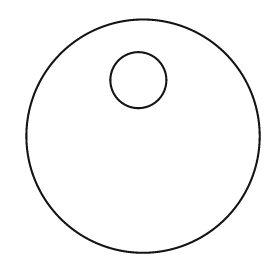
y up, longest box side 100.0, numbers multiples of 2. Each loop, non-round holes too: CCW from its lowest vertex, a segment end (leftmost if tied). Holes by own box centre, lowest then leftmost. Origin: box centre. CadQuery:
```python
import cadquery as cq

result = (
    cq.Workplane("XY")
    .moveTo(0.0, 0.0)
    .circle(50.0)
    .moveTo(-2.0, 24.0)
    .circle(12.0)
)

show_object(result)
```